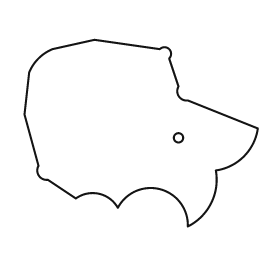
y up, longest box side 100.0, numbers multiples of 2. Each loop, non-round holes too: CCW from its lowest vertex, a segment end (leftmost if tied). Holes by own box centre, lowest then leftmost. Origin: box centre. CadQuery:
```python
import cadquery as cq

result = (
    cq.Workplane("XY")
    .moveTo(20.0, -40.0)
    .threePointArc((30.0, -30.0), (32.0, -16.0))
    .threePointArc((44.0, -10.0), (50.0, 2.0))
    .lineTo(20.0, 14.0)
    .threePointArc((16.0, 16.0), (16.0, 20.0))
    .lineTo(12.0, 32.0)
    .threePointArc((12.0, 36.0), (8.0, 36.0))
    .lineTo(-20.0, 40.0)
    .lineTo(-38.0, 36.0)
    .threePointArc((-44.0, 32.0), (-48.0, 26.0))
    .lineTo(-50.0, 8.0)
    .lineTo(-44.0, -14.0)
    .threePointArc((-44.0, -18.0), (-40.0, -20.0))
    .lineTo(-28.0, -28.0)
    .threePointArc((-18.0, -26.0), (-10.0, -32.0))
    .threePointArc((8.0, -24.0), (20.0, -40.0))
    .close()
    .moveTo(16.0, -2.0)
    .circle(2.0)
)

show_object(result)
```